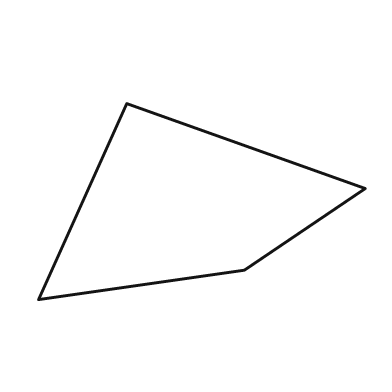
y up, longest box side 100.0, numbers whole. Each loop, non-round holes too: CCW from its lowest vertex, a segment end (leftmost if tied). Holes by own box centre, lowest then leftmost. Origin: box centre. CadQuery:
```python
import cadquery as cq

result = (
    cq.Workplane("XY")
    .moveTo(-50.0, -30.0)
    .lineTo(13.0, -21.0)
    .lineTo(50.0, 4.0)
    .lineTo(-23.0, 30.0)
    .close()
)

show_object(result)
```